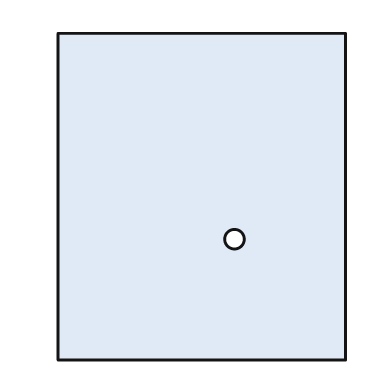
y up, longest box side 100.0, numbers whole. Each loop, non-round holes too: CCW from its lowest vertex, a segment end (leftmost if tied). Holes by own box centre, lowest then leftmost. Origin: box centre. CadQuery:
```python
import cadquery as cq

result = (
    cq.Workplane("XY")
    .moveTo(-44.0, -50.0)
    .lineTo(44.0, -50.0)
    .lineTo(44.0, 50.0)
    .lineTo(-44.0, 50.0)
    .close()
    .moveTo(10.0, -13.0)
    .circle(3.0)
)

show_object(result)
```